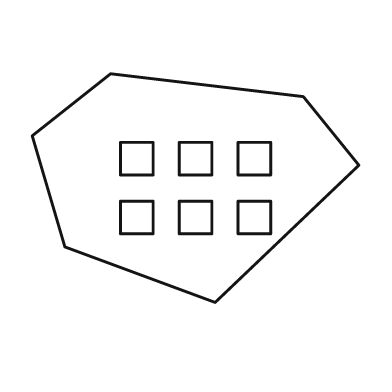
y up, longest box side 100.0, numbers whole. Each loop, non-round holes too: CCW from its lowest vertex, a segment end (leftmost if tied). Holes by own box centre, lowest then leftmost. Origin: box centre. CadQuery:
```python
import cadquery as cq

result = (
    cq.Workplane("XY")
    .moveTo(6.0, -35.0)
    .lineTo(50.0, 7.0)
    .lineTo(33.0, 28.0)
    .lineTo(-26.0, 35.0)
    .lineTo(-50.0, 16.0)
    .lineTo(-40.0, -18.0)
    .close()
    .moveTo(-23.0, -14.0)
    .lineTo(-13.0, -14.0)
    .lineTo(-13.0, -4.0)
    .lineTo(-23.0, -4.0)
    .close()
    .moveTo(-5.0, -14.0)
    .lineTo(5.0, -14.0)
    .lineTo(5.0, -4.0)
    .lineTo(-5.0, -4.0)
    .close()
    .moveTo(13.0, -14.0)
    .lineTo(23.0, -14.0)
    .lineTo(23.0, -4.0)
    .lineTo(13.0, -4.0)
    .close()
    .moveTo(-23.0, 4.0)
    .lineTo(-13.0, 4.0)
    .lineTo(-13.0, 14.0)
    .lineTo(-23.0, 14.0)
    .close()
    .moveTo(-5.0, 4.0)
    .lineTo(5.0, 4.0)
    .lineTo(5.0, 14.0)
    .lineTo(-5.0, 14.0)
    .close()
    .moveTo(13.0, 4.0)
    .lineTo(23.0, 4.0)
    .lineTo(23.0, 14.0)
    .lineTo(13.0, 14.0)
    .close()
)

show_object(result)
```